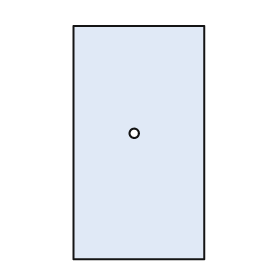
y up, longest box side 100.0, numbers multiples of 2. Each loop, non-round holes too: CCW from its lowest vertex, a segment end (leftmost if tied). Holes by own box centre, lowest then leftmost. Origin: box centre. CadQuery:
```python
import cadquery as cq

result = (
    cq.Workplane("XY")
    .moveTo(-28.0, -50.0)
    .lineTo(28.0, -50.0)
    .lineTo(28.0, 50.0)
    .lineTo(-28.0, 50.0)
    .close()
    .moveTo(-2.0, 4.0)
    .circle(2.0)
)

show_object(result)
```